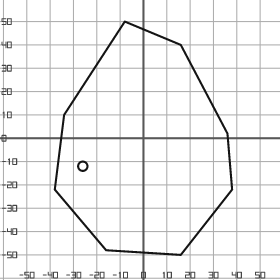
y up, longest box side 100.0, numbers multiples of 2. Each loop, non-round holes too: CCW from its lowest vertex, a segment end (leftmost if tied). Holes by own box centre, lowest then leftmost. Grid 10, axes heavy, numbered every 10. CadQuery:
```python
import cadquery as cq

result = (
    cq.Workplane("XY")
    .moveTo(16.0, -50.0)
    .lineTo(38.0, -22.0)
    .lineTo(36.0, 2.0)
    .lineTo(16.0, 40.0)
    .lineTo(-8.0, 50.0)
    .lineTo(-34.0, 10.0)
    .lineTo(-38.0, -22.0)
    .lineTo(-16.0, -48.0)
    .close()
    .moveTo(-26.0, -12.0)
    .circle(2.0)
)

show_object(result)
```